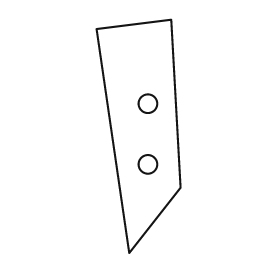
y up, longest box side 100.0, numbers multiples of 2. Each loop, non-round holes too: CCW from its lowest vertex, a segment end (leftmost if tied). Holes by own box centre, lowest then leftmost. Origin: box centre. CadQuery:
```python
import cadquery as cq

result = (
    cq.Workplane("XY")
    .moveTo(-4.0, -50.0)
    .lineTo(18.0, -22.0)
    .lineTo(14.0, 50.0)
    .lineTo(-18.0, 46.0)
    .close()
    .moveTo(4.0, -12.0)
    .circle(4.0)
    .moveTo(4.0, 14.0)
    .circle(4.0)
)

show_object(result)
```